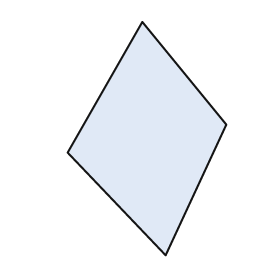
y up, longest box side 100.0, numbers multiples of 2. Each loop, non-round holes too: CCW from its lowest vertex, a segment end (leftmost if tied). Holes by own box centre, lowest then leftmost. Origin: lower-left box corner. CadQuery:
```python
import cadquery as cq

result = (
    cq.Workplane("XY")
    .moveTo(42.0, 0.0)
    .lineTo(68.0, 56.0)
    .lineTo(32.0, 100.0)
    .lineTo(0.0, 44.0)
    .close()
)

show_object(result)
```